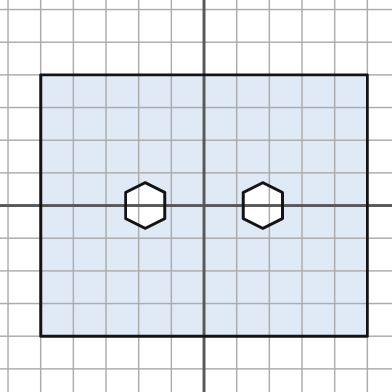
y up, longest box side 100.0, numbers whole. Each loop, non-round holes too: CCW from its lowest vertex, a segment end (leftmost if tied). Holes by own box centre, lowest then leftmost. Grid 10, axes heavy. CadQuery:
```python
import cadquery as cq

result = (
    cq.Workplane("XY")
    .moveTo(-50.0, -40.0)
    .lineTo(50.0, -40.0)
    .lineTo(50.0, 40.0)
    .lineTo(-50.0, 40.0)
    .close()
    .moveTo(-18.0, -7.0)
    .lineTo(-12.0, -4.0)
    .lineTo(-12.0, 4.0)
    .lineTo(-18.0, 7.0)
    .lineTo(-24.0, 4.0)
    .lineTo(-24.0, -4.0)
    .close()
    .moveTo(18.0, -7.0)
    .lineTo(24.0, -4.0)
    .lineTo(24.0, 4.0)
    .lineTo(18.0, 7.0)
    .lineTo(12.0, 4.0)
    .lineTo(12.0, -4.0)
    .close()
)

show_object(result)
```